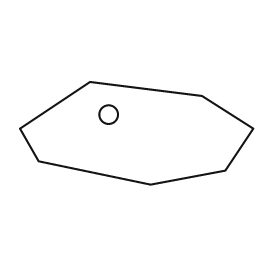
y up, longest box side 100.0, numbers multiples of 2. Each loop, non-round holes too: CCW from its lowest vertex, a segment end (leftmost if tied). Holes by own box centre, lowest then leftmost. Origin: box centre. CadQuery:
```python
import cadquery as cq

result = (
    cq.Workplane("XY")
    .moveTo(6.0, -22.0)
    .lineTo(38.0, -16.0)
    .lineTo(50.0, 2.0)
    .lineTo(28.0, 16.0)
    .lineTo(-20.0, 22.0)
    .lineTo(-50.0, 2.0)
    .lineTo(-42.0, -12.0)
    .close()
    .moveTo(-12.0, 8.0)
    .circle(4.0)
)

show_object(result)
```